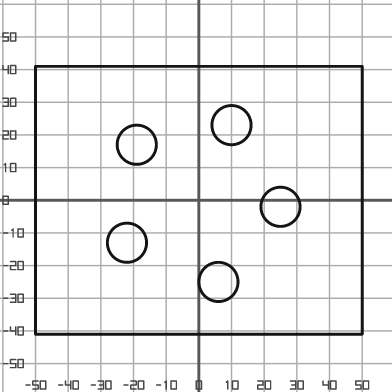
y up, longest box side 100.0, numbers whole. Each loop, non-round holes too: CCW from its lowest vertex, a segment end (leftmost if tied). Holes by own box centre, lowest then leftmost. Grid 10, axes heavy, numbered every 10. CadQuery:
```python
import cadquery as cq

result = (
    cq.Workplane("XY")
    .moveTo(-50.0, -41.0)
    .lineTo(50.0, -41.0)
    .lineTo(50.0, 41.0)
    .lineTo(-50.0, 41.0)
    .close()
    .moveTo(6.0, -25.0)
    .circle(6.0)
    .moveTo(-22.0, -13.0)
    .circle(6.0)
    .moveTo(25.0, -2.0)
    .circle(6.0)
    .moveTo(-19.0, 17.0)
    .circle(6.0)
    .moveTo(10.0, 23.0)
    .circle(6.0)
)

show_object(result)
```